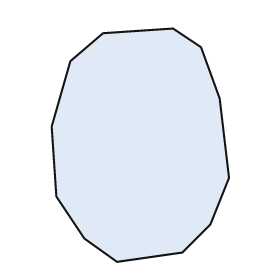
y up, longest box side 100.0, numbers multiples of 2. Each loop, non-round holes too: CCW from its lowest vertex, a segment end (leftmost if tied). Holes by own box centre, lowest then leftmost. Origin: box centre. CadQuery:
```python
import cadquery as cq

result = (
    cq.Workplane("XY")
    .moveTo(-10.0, -50.0)
    .lineTo(18.0, -46.0)
    .lineTo(30.0, -34.0)
    .lineTo(38.0, -14.0)
    .lineTo(34.0, 20.0)
    .lineTo(26.0, 42.0)
    .lineTo(14.0, 50.0)
    .lineTo(-16.0, 48.0)
    .lineTo(-30.0, 36.0)
    .lineTo(-38.0, 8.0)
    .lineTo(-36.0, -22.0)
    .lineTo(-24.0, -40.0)
    .close()
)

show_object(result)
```